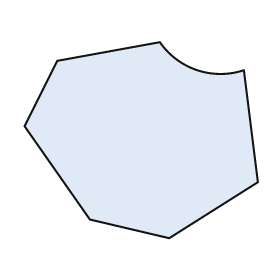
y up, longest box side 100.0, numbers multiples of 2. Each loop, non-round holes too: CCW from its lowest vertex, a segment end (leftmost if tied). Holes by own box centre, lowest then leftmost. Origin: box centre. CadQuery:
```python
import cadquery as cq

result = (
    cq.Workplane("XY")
    .moveTo(12.0, -42.0)
    .lineTo(50.0, -18.0)
    .lineTo(44.0, 30.0)
    .threePointArc((24.0, 30.0), (8.0, 42.0))
    .lineTo(-36.0, 34.0)
    .lineTo(-50.0, 6.0)
    .lineTo(-22.0, -34.0)
    .close()
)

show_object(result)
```